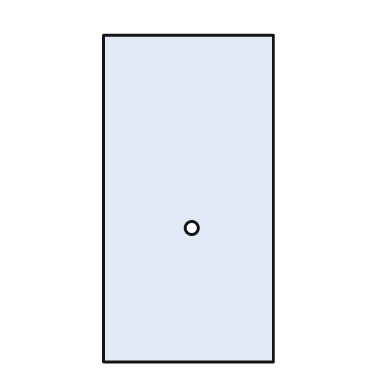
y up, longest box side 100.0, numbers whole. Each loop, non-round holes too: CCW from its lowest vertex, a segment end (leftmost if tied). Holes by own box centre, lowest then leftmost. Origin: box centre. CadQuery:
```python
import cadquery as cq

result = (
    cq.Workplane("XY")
    .moveTo(-26.0, -50.0)
    .lineTo(26.0, -50.0)
    .lineTo(26.0, 50.0)
    .lineTo(-26.0, 50.0)
    .close()
    .moveTo(1.0, -9.0)
    .circle(2.0)
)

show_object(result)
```